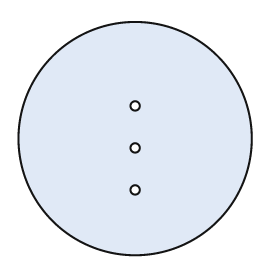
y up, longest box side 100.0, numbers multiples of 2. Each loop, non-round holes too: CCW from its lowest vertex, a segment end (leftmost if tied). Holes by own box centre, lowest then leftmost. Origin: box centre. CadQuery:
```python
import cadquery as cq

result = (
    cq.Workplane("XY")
    .moveTo(0.0, 0.0)
    .circle(50.0)
    .moveTo(0.0, -22.0)
    .circle(2.0)
    .moveTo(0.0, -4.0)
    .circle(2.0)
    .moveTo(0.0, 14.0)
    .circle(2.0)
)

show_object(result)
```